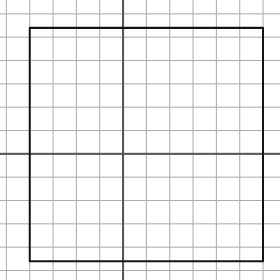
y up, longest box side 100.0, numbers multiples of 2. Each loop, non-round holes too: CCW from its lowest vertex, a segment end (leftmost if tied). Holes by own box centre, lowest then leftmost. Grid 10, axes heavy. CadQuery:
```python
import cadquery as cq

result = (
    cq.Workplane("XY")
    .moveTo(-40.0, -46.0)
    .lineTo(60.0, -46.0)
    .lineTo(60.0, 54.0)
    .lineTo(-40.0, 54.0)
    .close()
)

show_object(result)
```